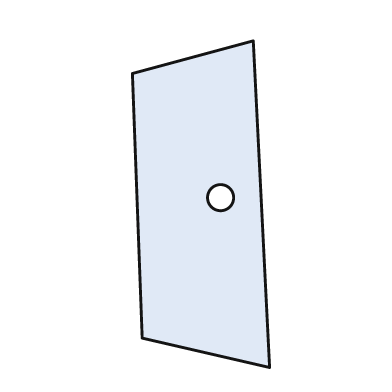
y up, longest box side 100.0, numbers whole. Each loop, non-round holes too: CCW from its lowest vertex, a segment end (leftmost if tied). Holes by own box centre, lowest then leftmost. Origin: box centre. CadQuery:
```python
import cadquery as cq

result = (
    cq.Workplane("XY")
    .moveTo(21.0, -50.0)
    .lineTo(16.0, 50.0)
    .lineTo(-21.0, 40.0)
    .lineTo(-18.0, -41.0)
    .close()
    .moveTo(6.0, 2.0)
    .circle(4.0)
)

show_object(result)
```